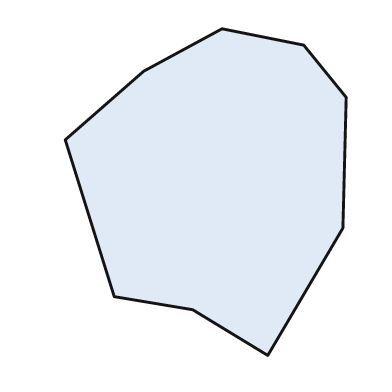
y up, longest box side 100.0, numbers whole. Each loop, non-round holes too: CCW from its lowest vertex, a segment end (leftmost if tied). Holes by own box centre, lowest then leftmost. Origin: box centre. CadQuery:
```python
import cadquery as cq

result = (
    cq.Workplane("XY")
    .moveTo(19.0, -50.0)
    .lineTo(42.0, -11.0)
    .lineTo(43.0, 29.0)
    .lineTo(30.0, 45.0)
    .lineTo(5.0, 50.0)
    .lineTo(-19.0, 37.0)
    .lineTo(-43.0, 16.0)
    .lineTo(-28.0, -32.0)
    .lineTo(-4.0, -36.0)
    .close()
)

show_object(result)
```